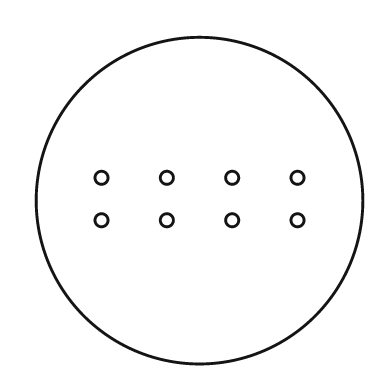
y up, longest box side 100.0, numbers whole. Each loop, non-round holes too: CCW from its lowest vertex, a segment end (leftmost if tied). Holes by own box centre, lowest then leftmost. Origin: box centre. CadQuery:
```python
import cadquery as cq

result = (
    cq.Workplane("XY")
    .moveTo(0.0, 0.0)
    .circle(50.0)
    .moveTo(-30.0, -6.0)
    .circle(2.0)
    .moveTo(-10.0, -6.0)
    .circle(2.0)
    .moveTo(10.0, -6.0)
    .circle(2.0)
    .moveTo(30.0, -6.0)
    .circle(2.0)
    .moveTo(-30.0, 7.0)
    .circle(2.0)
    .moveTo(-10.0, 7.0)
    .circle(2.0)
    .moveTo(10.0, 7.0)
    .circle(2.0)
    .moveTo(30.0, 7.0)
    .circle(2.0)
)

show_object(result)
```